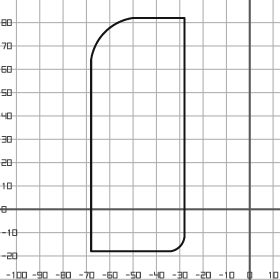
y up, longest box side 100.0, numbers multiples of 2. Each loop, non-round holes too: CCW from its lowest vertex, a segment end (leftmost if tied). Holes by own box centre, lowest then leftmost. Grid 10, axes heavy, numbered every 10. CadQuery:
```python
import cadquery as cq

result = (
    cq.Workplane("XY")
    .moveTo(-68.0, -18.0)
    .lineTo(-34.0, -18.0)
    .threePointArc((-30.0, -16.0), (-28.0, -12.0))
    .lineTo(-28.0, 82.0)
    .lineTo(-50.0, 82.0)
    .threePointArc((-62.0, 76.0), (-68.0, 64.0))
    .close()
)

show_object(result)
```